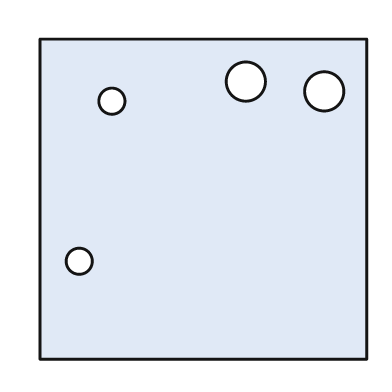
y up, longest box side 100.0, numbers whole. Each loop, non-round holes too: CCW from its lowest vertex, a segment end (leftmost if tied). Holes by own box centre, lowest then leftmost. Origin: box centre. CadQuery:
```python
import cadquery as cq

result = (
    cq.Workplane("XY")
    .moveTo(-50.0, -49.0)
    .lineTo(50.0, -49.0)
    .lineTo(50.0, 49.0)
    .lineTo(-50.0, 49.0)
    .close()
    .moveTo(-38.0, -19.0)
    .circle(4.0)
    .moveTo(-28.0, 30.0)
    .circle(4.0)
    .moveTo(37.0, 33.0)
    .circle(6.0)
    .moveTo(13.0, 36.0)
    .circle(6.0)
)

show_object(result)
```